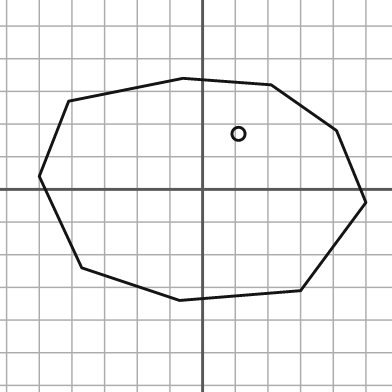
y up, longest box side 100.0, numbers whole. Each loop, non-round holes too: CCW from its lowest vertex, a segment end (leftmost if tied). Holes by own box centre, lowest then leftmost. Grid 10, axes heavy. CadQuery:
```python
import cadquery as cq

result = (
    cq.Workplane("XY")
    .moveTo(-7.0, -34.0)
    .lineTo(30.0, -31.0)
    .lineTo(50.0, -4.0)
    .lineTo(41.0, 18.0)
    .lineTo(21.0, 32.0)
    .lineTo(-6.0, 34.0)
    .lineTo(-41.0, 27.0)
    .lineTo(-50.0, 4.0)
    .lineTo(-37.0, -24.0)
    .close()
    .moveTo(11.0, 17.0)
    .circle(2.0)
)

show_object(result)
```